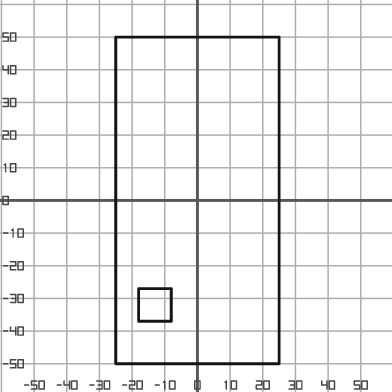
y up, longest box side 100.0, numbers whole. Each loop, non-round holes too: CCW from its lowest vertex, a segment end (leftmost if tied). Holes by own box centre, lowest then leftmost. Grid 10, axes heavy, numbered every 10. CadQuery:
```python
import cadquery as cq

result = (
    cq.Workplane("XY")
    .moveTo(-25.0, -50.0)
    .lineTo(25.0, -50.0)
    .lineTo(25.0, 50.0)
    .lineTo(-25.0, 50.0)
    .close()
    .moveTo(-18.0, -37.0)
    .lineTo(-8.0, -37.0)
    .lineTo(-8.0, -27.0)
    .lineTo(-18.0, -27.0)
    .close()
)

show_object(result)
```